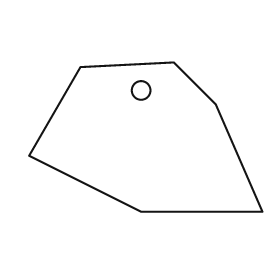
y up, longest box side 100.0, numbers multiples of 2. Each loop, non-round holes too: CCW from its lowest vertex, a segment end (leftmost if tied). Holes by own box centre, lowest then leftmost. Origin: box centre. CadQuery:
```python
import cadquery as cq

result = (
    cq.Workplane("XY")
    .moveTo(-2.0, -32.0)
    .lineTo(50.0, -32.0)
    .lineTo(30.0, 14.0)
    .lineTo(12.0, 32.0)
    .lineTo(-28.0, 30.0)
    .lineTo(-50.0, -8.0)
    .close()
    .moveTo(-2.0, 20.0)
    .circle(4.0)
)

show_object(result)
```